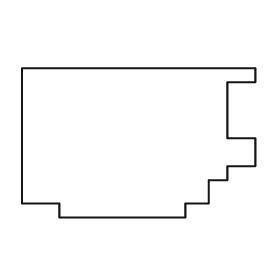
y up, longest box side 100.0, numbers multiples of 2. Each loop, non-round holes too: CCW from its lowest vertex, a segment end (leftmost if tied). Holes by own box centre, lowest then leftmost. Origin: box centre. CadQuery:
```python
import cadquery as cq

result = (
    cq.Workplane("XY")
    .moveTo(-34.0, -32.0)
    .lineTo(20.0, -32.0)
    .lineTo(20.0, -26.0)
    .lineTo(30.0, -26.0)
    .lineTo(30.0, -16.0)
    .lineTo(38.0, -16.0)
    .lineTo(38.0, -10.0)
    .lineTo(50.0, -10.0)
    .lineTo(50.0, 2.0)
    .lineTo(38.0, 2.0)
    .lineTo(38.0, 26.0)
    .lineTo(50.0, 26.0)
    .lineTo(50.0, 32.0)
    .lineTo(-50.0, 32.0)
    .lineTo(-50.0, -26.0)
    .lineTo(-34.0, -26.0)
    .close()
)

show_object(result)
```